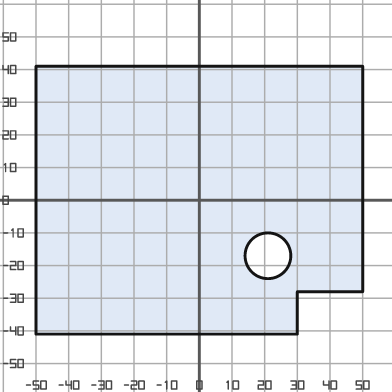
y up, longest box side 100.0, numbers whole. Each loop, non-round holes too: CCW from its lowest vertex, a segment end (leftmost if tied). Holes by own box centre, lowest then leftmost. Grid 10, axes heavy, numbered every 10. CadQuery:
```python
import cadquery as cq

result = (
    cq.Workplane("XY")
    .moveTo(-50.0, -41.0)
    .lineTo(30.0, -41.0)
    .lineTo(30.0, -28.0)
    .lineTo(50.0, -28.0)
    .lineTo(50.0, 41.0)
    .lineTo(-50.0, 41.0)
    .close()
    .moveTo(21.0, -17.0)
    .circle(7.0)
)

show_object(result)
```